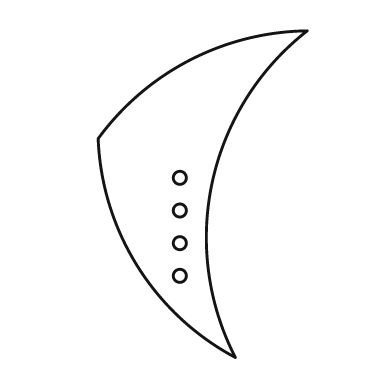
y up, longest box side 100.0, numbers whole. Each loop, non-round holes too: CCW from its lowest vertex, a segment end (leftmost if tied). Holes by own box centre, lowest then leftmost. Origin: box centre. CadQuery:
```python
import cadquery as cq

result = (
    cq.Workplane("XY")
    .moveTo(10.0, -50.0)
    .threePointArc((3.0, 4.0), (32.0, 50.0))
    .threePointArc((-4.0, 41.0), (-32.0, 17.0))
    .threePointArc((-20.0, -22.0), (10.0, -50.0))
    .close()
    .moveTo(-7.0, -25.0)
    .circle(2.0)
    .moveTo(-7.0, -15.0)
    .circle(2.0)
    .moveTo(-7.0, -5.0)
    .circle(2.0)
    .moveTo(-7.0, 5.0)
    .circle(2.0)
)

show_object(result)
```